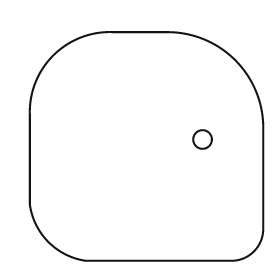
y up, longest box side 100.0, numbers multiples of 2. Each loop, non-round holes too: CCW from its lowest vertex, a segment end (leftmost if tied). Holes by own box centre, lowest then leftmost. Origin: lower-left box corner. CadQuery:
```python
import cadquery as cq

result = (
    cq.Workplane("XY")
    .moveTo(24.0, 0.0)
    .lineTo(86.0, 0.0)
    .threePointArc((96.0, 4.0), (100.0, 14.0))
    .lineTo(100.0, 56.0)
    .threePointArc((88.0, 86.0), (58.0, 98.0))
    .lineTo(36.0, 98.0)
    .threePointArc((10.0, 88.0), (0.0, 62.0))
    .lineTo(0.0, 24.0)
    .threePointArc((8.0, 8.0), (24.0, 0.0))
    .close()
    .moveTo(74.0, 52.0)
    .circle(4.0)
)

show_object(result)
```